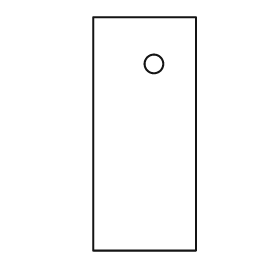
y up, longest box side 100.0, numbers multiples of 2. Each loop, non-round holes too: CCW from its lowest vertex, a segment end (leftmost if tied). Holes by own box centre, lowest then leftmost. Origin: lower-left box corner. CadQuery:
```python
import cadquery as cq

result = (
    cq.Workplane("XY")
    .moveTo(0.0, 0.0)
    .lineTo(44.0, 0.0)
    .lineTo(44.0, 100.0)
    .lineTo(0.0, 100.0)
    .close()
    .moveTo(26.0, 80.0)
    .circle(4.0)
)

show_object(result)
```